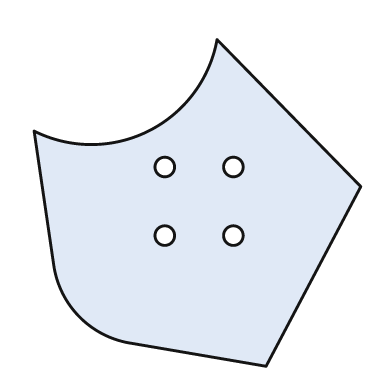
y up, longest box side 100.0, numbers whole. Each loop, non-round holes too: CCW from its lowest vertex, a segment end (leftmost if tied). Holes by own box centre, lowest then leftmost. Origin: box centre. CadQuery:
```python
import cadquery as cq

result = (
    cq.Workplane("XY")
    .moveTo(21.0, -50.0)
    .lineTo(50.0, 5.0)
    .lineTo(6.0, 50.0)
    .threePointArc((-15.0, 22.0), (-50.0, 22.0))
    .lineTo(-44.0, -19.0)
    .threePointArc((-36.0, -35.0), (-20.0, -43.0))
    .close()
    .moveTo(-10.0, -10.0)
    .circle(3.0)
    .moveTo(11.0, -10.0)
    .circle(3.0)
    .moveTo(-10.0, 11.0)
    .circle(3.0)
    .moveTo(11.0, 11.0)
    .circle(3.0)
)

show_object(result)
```